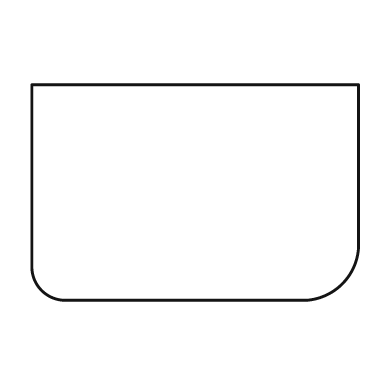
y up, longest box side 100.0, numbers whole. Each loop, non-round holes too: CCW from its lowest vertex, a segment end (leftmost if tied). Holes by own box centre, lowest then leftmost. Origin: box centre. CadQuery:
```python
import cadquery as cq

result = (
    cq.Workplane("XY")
    .moveTo(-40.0, -33.0)
    .lineTo(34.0, -33.0)
    .threePointArc((45.0, -28.0), (50.0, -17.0))
    .lineTo(50.0, 33.0)
    .lineTo(-50.0, 33.0)
    .lineTo(-50.0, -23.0)
    .threePointArc((-47.0, -30.0), (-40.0, -33.0))
    .close()
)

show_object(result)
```